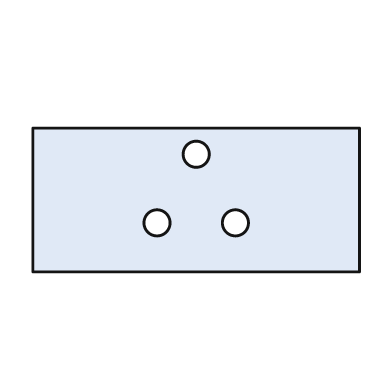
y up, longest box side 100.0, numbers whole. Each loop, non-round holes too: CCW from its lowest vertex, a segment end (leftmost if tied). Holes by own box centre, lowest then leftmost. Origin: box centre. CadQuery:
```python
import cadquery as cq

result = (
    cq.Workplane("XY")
    .moveTo(-50.0, -22.0)
    .lineTo(50.0, -22.0)
    .lineTo(50.0, 22.0)
    .lineTo(-50.0, 22.0)
    .close()
    .moveTo(-12.0, -7.0)
    .circle(4.0)
    .moveTo(12.0, -7.0)
    .circle(4.0)
    .moveTo(0.0, 14.0)
    .circle(4.0)
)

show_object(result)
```